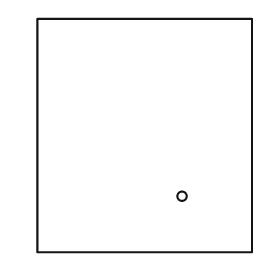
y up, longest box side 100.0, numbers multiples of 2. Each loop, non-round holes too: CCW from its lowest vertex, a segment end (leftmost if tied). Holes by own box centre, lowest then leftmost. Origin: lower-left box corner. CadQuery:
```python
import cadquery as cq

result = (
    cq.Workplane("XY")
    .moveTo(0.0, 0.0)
    .lineTo(92.0, 0.0)
    .lineTo(92.0, 100.0)
    .lineTo(0.0, 100.0)
    .close()
    .moveTo(62.0, 24.0)
    .circle(2.0)
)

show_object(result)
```